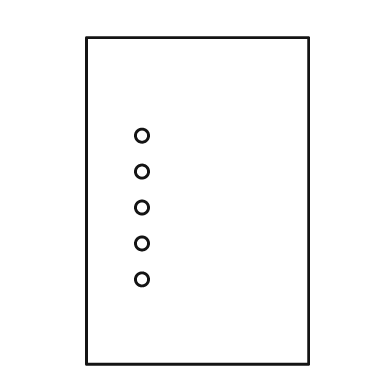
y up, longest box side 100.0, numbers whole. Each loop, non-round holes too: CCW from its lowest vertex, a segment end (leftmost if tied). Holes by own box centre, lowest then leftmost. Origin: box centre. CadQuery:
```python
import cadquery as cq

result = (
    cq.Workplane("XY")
    .moveTo(-34.0, -50.0)
    .lineTo(34.0, -50.0)
    .lineTo(34.0, 50.0)
    .lineTo(-34.0, 50.0)
    .close()
    .moveTo(-17.0, -24.0)
    .circle(2.0)
    .moveTo(-17.0, -13.0)
    .circle(2.0)
    .moveTo(-17.0, -2.0)
    .circle(2.0)
    .moveTo(-17.0, 9.0)
    .circle(2.0)
    .moveTo(-17.0, 20.0)
    .circle(2.0)
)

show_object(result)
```